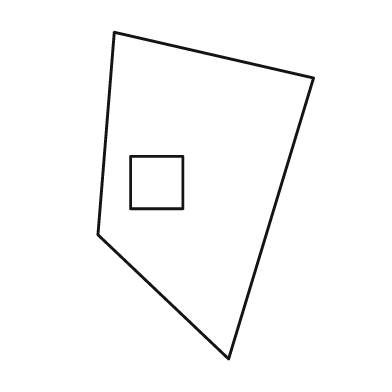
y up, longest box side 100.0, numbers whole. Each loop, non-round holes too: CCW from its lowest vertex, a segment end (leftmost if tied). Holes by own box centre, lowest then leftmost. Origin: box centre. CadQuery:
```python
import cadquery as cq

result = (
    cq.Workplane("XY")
    .moveTo(7.0, -50.0)
    .lineTo(33.0, 36.0)
    .lineTo(-28.0, 50.0)
    .lineTo(-33.0, -12.0)
    .close()
    .moveTo(-23.0, -4.0)
    .lineTo(-7.0, -4.0)
    .lineTo(-7.0, 12.0)
    .lineTo(-23.0, 12.0)
    .close()
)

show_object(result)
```